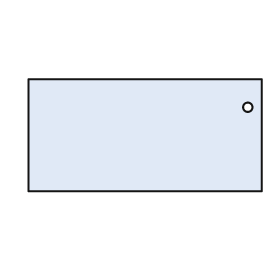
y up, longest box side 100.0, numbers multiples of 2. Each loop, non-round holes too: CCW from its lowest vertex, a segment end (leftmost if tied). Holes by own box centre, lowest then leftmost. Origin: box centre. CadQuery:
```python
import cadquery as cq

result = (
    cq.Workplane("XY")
    .moveTo(-50.0, -24.0)
    .lineTo(50.0, -24.0)
    .lineTo(50.0, 24.0)
    .lineTo(-50.0, 24.0)
    .close()
    .moveTo(44.0, 12.0)
    .circle(2.0)
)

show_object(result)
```